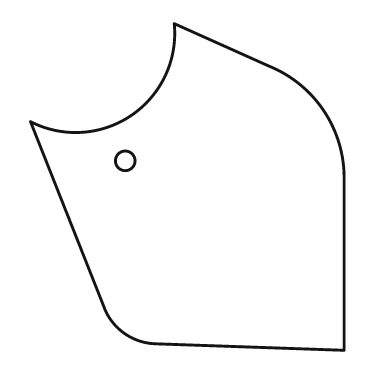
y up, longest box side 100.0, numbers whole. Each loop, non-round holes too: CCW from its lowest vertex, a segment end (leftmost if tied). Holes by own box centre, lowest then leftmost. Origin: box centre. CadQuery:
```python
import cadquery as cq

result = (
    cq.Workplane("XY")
    .moveTo(48.0, -50.0)
    .lineTo(48.0, 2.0)
    .threePointArc((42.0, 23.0), (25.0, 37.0))
    .lineTo(-4.0, 50.0)
    .threePointArc((-17.0, 22.0), (-48.0, 20.0))
    .lineTo(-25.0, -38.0)
    .threePointArc((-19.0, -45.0), (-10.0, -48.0))
    .close()
    .moveTo(-19.0, 8.0)
    .circle(3.0)
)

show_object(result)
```